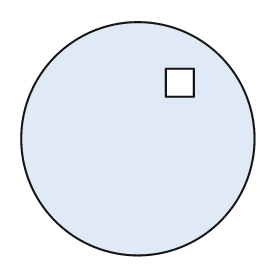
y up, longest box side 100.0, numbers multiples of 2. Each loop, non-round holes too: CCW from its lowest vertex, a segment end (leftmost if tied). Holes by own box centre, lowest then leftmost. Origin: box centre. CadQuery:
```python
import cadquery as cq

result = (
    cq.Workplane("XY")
    .moveTo(0.0, 0.0)
    .circle(50.0)
    .moveTo(12.0, 18.0)
    .lineTo(24.0, 18.0)
    .lineTo(24.0, 30.0)
    .lineTo(12.0, 30.0)
    .close()
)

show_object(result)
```